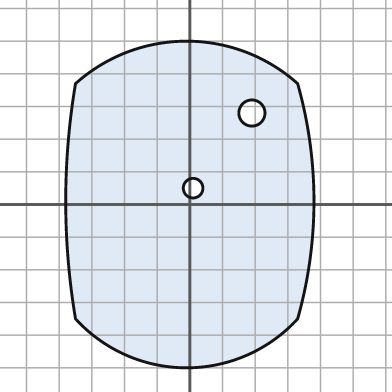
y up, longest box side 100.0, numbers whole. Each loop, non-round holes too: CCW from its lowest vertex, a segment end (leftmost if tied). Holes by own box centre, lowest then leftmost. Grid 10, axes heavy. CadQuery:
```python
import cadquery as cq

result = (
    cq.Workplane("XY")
    .moveTo(-35.0, -35.0)
    .threePointArc((-1.0, -50.0), (33.0, -35.0))
    .threePointArc((38.0, 1.0), (33.0, 37.0))
    .threePointArc((-1.0, 50.0), (-35.0, 37.0))
    .threePointArc((-38.0, 1.0), (-35.0, -35.0))
    .close()
    .moveTo(1.0, 5.0)
    .circle(3.0)
    .moveTo(19.0, 28.0)
    .circle(4.0)
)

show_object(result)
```